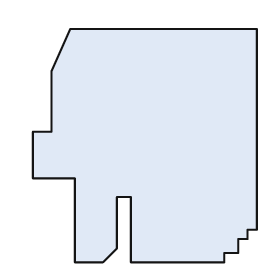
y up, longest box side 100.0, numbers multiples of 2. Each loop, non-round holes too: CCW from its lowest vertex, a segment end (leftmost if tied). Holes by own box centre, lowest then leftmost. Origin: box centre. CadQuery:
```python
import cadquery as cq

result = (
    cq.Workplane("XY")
    .moveTo(-30.0, -50.0)
    .lineTo(-18.0, -50.0)
    .lineTo(-12.0, -44.0)
    .lineTo(-12.0, -22.0)
    .lineTo(-6.0, -22.0)
    .lineTo(-6.0, -50.0)
    .lineTo(34.0, -50.0)
    .lineTo(34.0, -46.0)
    .lineTo(40.0, -46.0)
    .lineTo(40.0, -40.0)
    .lineTo(44.0, -40.0)
    .lineTo(44.0, -36.0)
    .lineTo(48.0, -36.0)
    .lineTo(48.0, 50.0)
    .lineTo(-32.0, 50.0)
    .lineTo(-40.0, 32.0)
    .lineTo(-40.0, 6.0)
    .lineTo(-48.0, 6.0)
    .lineTo(-48.0, -14.0)
    .lineTo(-30.0, -14.0)
    .close()
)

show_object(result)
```